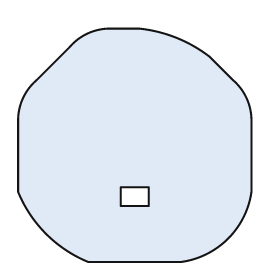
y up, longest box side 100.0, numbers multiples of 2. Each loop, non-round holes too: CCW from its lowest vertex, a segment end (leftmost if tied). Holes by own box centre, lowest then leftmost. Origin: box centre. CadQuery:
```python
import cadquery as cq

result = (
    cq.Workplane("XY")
    .moveTo(-20.0, -50.0)
    .lineTo(20.0, -50.0)
    .threePointArc((40.0, -40.0), (50.0, -20.0))
    .lineTo(50.0, 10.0)
    .threePointArc((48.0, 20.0), (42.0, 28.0))
    .lineTo(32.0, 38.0)
    .threePointArc((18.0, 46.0), (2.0, 50.0))
    .lineTo(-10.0, 50.0)
    .threePointArc((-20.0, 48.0), (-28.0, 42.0))
    .lineTo(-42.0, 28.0)
    .threePointArc((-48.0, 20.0), (-50.0, 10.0))
    .lineTo(-50.0, -20.0)
    .threePointArc((-38.0, -38.0), (-20.0, -50.0))
    .close()
    .moveTo(-6.0, -26.0)
    .lineTo(6.0, -26.0)
    .lineTo(6.0, -18.0)
    .lineTo(-6.0, -18.0)
    .close()
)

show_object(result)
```